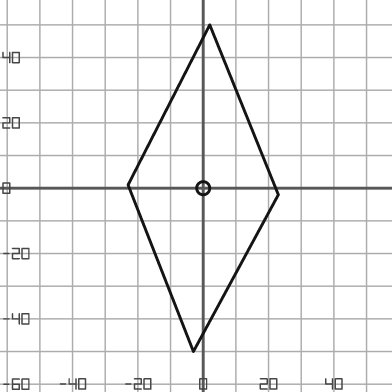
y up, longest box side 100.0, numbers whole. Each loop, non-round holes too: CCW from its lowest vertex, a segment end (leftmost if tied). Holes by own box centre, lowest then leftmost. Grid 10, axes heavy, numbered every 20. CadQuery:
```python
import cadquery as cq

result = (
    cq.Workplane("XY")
    .moveTo(-3.0, -50.0)
    .lineTo(23.0, -2.0)
    .lineTo(2.0, 50.0)
    .lineTo(-23.0, 1.0)
    .close()
    .moveTo(0.0, 0.0)
    .circle(2.0)
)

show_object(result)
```